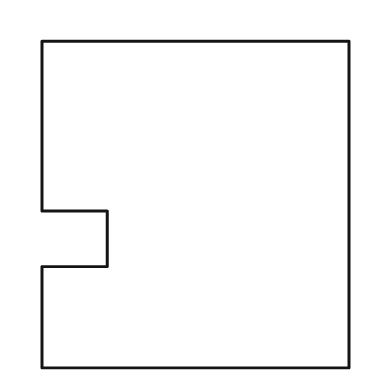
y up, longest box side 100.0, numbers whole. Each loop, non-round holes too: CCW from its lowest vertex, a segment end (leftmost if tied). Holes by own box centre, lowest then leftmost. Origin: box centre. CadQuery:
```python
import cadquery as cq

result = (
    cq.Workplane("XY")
    .moveTo(-47.0, -50.0)
    .lineTo(47.0, -50.0)
    .lineTo(47.0, 50.0)
    .lineTo(-47.0, 50.0)
    .lineTo(-47.0, -2.0)
    .lineTo(-27.0, -2.0)
    .lineTo(-27.0, -19.0)
    .lineTo(-47.0, -19.0)
    .close()
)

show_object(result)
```